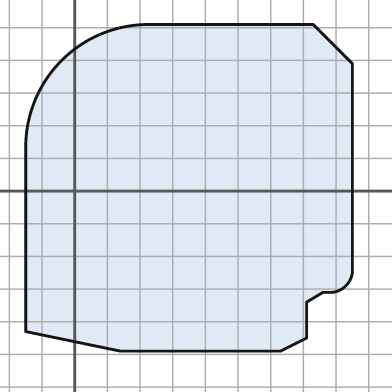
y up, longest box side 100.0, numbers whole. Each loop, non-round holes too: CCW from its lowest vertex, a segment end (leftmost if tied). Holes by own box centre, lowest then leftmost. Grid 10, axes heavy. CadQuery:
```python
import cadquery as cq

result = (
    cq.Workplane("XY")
    .moveTo(14.0, -49.0)
    .lineTo(63.0, -49.0)
    .lineTo(71.0, -45.0)
    .lineTo(71.0, -34.0)
    .lineTo(76.0, -31.0)
    .lineTo(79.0, -31.0)
    .threePointArc((83.0, -29.0), (85.0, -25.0))
    .lineTo(85.0, 39.0)
    .lineTo(73.0, 51.0)
    .lineTo(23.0, 51.0)
    .threePointArc((-4.0, 40.0), (-15.0, 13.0))
    .lineTo(-15.0, -43.0)
    .close()
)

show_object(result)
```